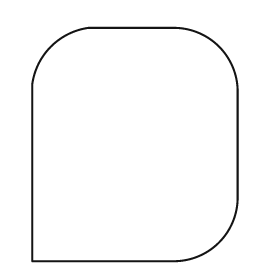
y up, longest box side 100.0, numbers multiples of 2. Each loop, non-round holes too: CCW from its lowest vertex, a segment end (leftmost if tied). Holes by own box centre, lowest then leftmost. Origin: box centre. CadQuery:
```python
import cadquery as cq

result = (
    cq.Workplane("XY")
    .moveTo(-44.0, -50.0)
    .lineTo(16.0, -50.0)
    .threePointArc((36.0, -42.0), (44.0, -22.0))
    .lineTo(44.0, 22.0)
    .threePointArc((36.0, 42.0), (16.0, 50.0))
    .lineTo(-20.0, 50.0)
    .threePointArc((-36.0, 42.0), (-44.0, 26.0))
    .close()
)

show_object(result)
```